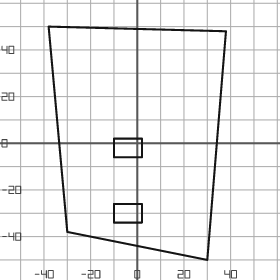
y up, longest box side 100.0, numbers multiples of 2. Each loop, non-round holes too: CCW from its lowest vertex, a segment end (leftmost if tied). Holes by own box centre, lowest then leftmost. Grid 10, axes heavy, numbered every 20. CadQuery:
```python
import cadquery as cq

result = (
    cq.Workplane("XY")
    .moveTo(30.0, -50.0)
    .lineTo(38.0, 48.0)
    .lineTo(-38.0, 50.0)
    .lineTo(-30.0, -38.0)
    .close()
    .moveTo(-10.0, -34.0)
    .lineTo(2.0, -34.0)
    .lineTo(2.0, -26.0)
    .lineTo(-10.0, -26.0)
    .close()
    .moveTo(-10.0, -6.0)
    .lineTo(2.0, -6.0)
    .lineTo(2.0, 2.0)
    .lineTo(-10.0, 2.0)
    .close()
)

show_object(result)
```